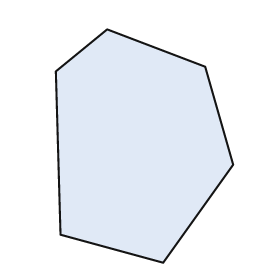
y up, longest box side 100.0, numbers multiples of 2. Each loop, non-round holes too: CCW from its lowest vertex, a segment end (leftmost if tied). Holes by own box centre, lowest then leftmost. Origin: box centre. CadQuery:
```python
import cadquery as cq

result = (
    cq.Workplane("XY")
    .moveTo(8.0, -50.0)
    .lineTo(38.0, -8.0)
    .lineTo(26.0, 34.0)
    .lineTo(-16.0, 50.0)
    .lineTo(-38.0, 32.0)
    .lineTo(-36.0, -38.0)
    .close()
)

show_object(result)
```